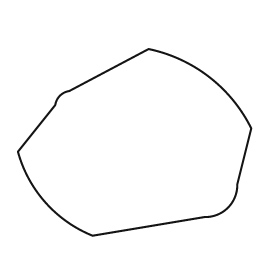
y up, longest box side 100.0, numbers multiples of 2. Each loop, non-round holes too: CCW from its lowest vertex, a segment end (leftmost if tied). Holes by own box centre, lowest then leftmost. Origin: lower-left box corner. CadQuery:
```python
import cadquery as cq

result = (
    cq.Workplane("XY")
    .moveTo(32.0, 0.0)
    .lineTo(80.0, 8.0)
    .threePointArc((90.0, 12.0), (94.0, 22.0))
    .lineTo(100.0, 46.0)
    .threePointArc((82.0, 68.0), (56.0, 80.0))
    .lineTo(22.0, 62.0)
    .threePointArc((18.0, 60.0), (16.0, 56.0))
    .lineTo(0.0, 36.0)
    .threePointArc((12.0, 14.0), (32.0, 0.0))
    .close()
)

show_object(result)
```